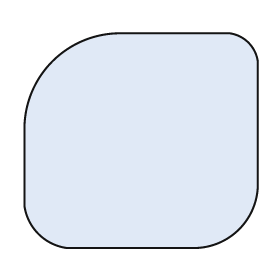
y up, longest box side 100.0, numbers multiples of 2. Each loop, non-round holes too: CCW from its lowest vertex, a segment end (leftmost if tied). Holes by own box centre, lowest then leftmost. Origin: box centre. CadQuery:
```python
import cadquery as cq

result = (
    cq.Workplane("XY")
    .moveTo(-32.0, -46.0)
    .lineTo(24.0, -46.0)
    .threePointArc((42.0, -38.0), (50.0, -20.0))
    .lineTo(50.0, 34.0)
    .threePointArc((46.0, 42.0), (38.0, 46.0))
    .lineTo(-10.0, 46.0)
    .threePointArc((-38.0, 34.0), (-50.0, 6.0))
    .lineTo(-50.0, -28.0)
    .threePointArc((-44.0, -40.0), (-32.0, -46.0))
    .close()
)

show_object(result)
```